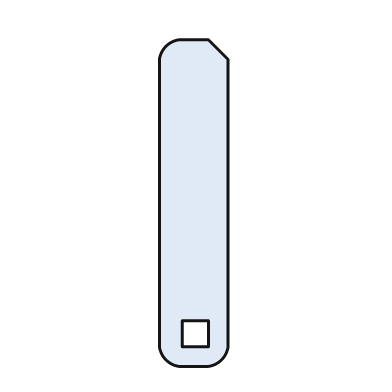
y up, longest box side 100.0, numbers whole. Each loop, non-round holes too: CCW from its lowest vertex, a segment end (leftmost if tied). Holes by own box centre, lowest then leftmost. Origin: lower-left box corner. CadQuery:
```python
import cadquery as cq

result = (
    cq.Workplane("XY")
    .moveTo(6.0, 0.0)
    .lineTo(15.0, 0.0)
    .threePointArc((19.0, 2.0), (21.0, 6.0))
    .lineTo(21.0, 94.0)
    .lineTo(15.0, 100.0)
    .lineTo(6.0, 100.0)
    .threePointArc((2.0, 98.0), (0.0, 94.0))
    .lineTo(0.0, 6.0)
    .threePointArc((2.0, 2.0), (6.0, 0.0))
    .close()
    .moveTo(7.0, 6.0)
    .lineTo(15.0, 6.0)
    .lineTo(15.0, 14.0)
    .lineTo(7.0, 14.0)
    .close()
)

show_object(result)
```